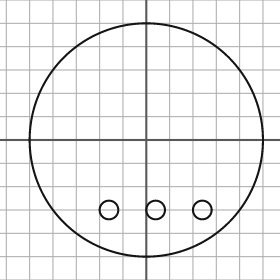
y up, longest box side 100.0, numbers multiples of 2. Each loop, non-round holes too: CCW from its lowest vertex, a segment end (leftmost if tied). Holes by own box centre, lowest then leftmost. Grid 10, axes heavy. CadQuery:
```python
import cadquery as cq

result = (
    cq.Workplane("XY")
    .moveTo(0.0, 0.0)
    .circle(50.0)
    .moveTo(-16.0, -30.0)
    .circle(4.0)
    .moveTo(4.0, -30.0)
    .circle(4.0)
    .moveTo(24.0, -30.0)
    .circle(4.0)
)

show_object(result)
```